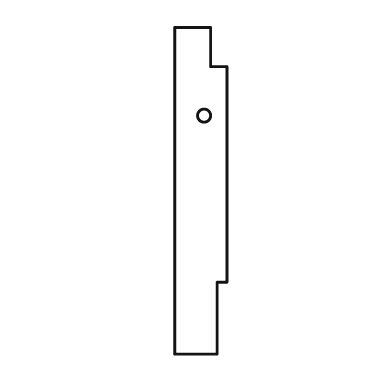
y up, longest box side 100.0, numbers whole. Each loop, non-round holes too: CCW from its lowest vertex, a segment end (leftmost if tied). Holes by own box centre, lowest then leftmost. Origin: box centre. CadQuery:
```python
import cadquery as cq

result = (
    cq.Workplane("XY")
    .moveTo(-8.0, -50.0)
    .lineTo(5.0, -50.0)
    .lineTo(5.0, -28.0)
    .lineTo(8.0, -28.0)
    .lineTo(8.0, 38.0)
    .lineTo(3.0, 38.0)
    .lineTo(3.0, 50.0)
    .lineTo(-8.0, 50.0)
    .close()
    .moveTo(1.0, 23.0)
    .circle(2.0)
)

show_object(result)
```